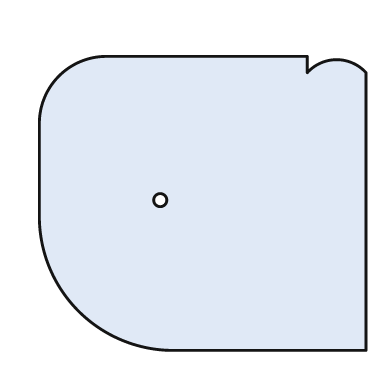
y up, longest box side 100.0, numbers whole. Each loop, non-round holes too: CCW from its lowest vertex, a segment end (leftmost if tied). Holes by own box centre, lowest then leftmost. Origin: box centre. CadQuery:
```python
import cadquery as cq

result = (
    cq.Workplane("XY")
    .moveTo(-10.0, -45.0)
    .lineTo(50.0, -45.0)
    .lineTo(50.0, 40.0)
    .threePointArc((41.0, 44.0), (32.0, 40.0))
    .lineTo(32.0, 45.0)
    .lineTo(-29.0, 45.0)
    .threePointArc((-44.0, 39.0), (-50.0, 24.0))
    .lineTo(-50.0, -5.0)
    .threePointArc((-38.0, -33.0), (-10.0, -45.0))
    .close()
    .moveTo(-13.0, 1.0)
    .circle(2.0)
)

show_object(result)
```